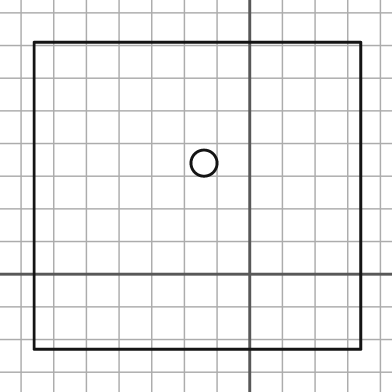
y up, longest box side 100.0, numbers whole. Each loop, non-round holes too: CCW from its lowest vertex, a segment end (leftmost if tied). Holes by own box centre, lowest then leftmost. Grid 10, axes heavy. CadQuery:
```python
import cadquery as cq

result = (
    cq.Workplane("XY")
    .moveTo(-66.0, -23.0)
    .lineTo(34.0, -23.0)
    .lineTo(34.0, 71.0)
    .lineTo(-66.0, 71.0)
    .close()
    .moveTo(-14.0, 34.0)
    .circle(4.0)
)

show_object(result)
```